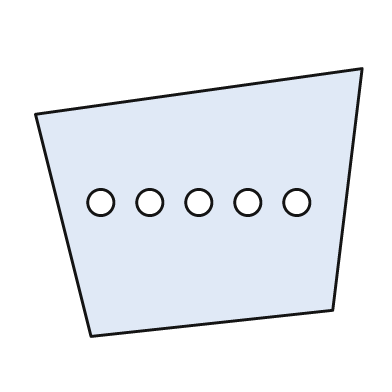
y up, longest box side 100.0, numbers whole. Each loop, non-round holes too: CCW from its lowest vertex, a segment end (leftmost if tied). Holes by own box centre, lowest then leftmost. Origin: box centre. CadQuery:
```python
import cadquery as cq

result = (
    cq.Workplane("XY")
    .moveTo(-33.0, -41.0)
    .lineTo(41.0, -33.0)
    .lineTo(50.0, 41.0)
    .lineTo(-50.0, 27.0)
    .close()
    .moveTo(-30.0, 0.0)
    .circle(4.0)
    .moveTo(-15.0, 0.0)
    .circle(4.0)
    .moveTo(0.0, 0.0)
    .circle(4.0)
    .moveTo(15.0, 0.0)
    .circle(4.0)
    .moveTo(30.0, 0.0)
    .circle(4.0)
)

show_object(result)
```